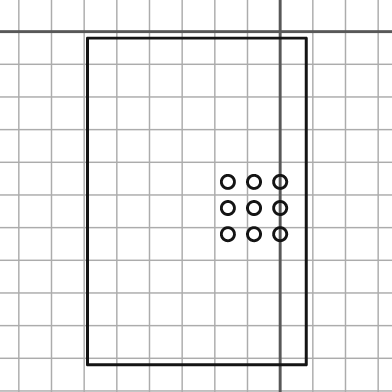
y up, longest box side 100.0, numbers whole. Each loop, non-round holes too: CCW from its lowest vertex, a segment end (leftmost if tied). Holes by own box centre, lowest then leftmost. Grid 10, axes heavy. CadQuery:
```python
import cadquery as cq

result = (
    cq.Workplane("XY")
    .moveTo(-59.0, -102.0)
    .lineTo(8.0, -102.0)
    .lineTo(8.0, -2.0)
    .lineTo(-59.0, -2.0)
    .close()
    .moveTo(-16.0, -62.0)
    .circle(2.0)
    .moveTo(-8.0, -62.0)
    .circle(2.0)
    .moveTo(0.0, -62.0)
    .circle(2.0)
    .moveTo(-16.0, -54.0)
    .circle(2.0)
    .moveTo(-8.0, -54.0)
    .circle(2.0)
    .moveTo(0.0, -54.0)
    .circle(2.0)
    .moveTo(-16.0, -46.0)
    .circle(2.0)
    .moveTo(-8.0, -46.0)
    .circle(2.0)
    .moveTo(0.0, -46.0)
    .circle(2.0)
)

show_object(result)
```